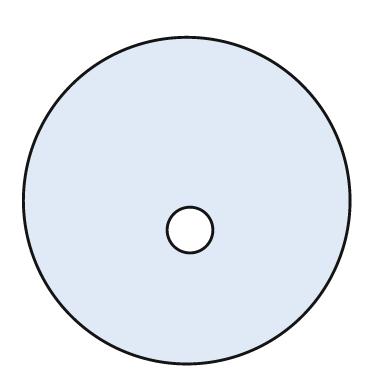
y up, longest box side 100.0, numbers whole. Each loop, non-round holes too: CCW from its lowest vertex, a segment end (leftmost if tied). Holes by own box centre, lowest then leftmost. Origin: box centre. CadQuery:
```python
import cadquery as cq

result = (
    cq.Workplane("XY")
    .moveTo(0.0, 0.0)
    .circle(50.0)
    .moveTo(1.0, -9.0)
    .circle(7.0)
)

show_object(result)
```